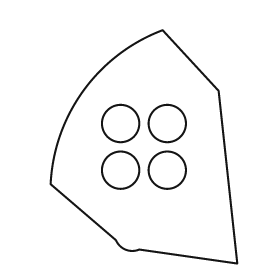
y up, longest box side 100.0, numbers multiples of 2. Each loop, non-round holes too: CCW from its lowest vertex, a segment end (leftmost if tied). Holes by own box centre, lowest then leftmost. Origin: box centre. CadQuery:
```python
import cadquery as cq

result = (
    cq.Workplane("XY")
    .moveTo(40.0, -50.0)
    .lineTo(32.0, 24.0)
    .lineTo(8.0, 50.0)
    .threePointArc((-26.0, 24.0), (-40.0, -16.0))
    .lineTo(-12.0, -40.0)
    .threePointArc((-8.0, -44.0), (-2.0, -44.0))
    .close()
    .moveTo(-10.0, -10.0)
    .circle(8.0)
    .moveTo(10.0, -10.0)
    .circle(8.0)
    .moveTo(-10.0, 10.0)
    .circle(8.0)
    .moveTo(10.0, 10.0)
    .circle(8.0)
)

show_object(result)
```